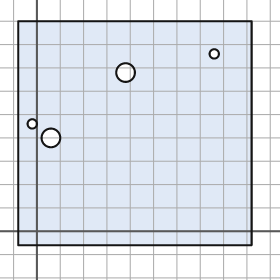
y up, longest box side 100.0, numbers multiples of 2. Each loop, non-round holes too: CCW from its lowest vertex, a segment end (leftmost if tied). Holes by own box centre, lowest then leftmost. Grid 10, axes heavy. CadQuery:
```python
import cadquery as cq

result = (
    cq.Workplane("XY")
    .moveTo(-8.0, -6.0)
    .lineTo(92.0, -6.0)
    .lineTo(92.0, 90.0)
    .lineTo(-8.0, 90.0)
    .close()
    .moveTo(6.0, 40.0)
    .circle(4.0)
    .moveTo(-2.0, 46.0)
    .circle(2.0)
    .moveTo(38.0, 68.0)
    .circle(4.0)
    .moveTo(76.0, 76.0)
    .circle(2.0)
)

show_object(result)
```